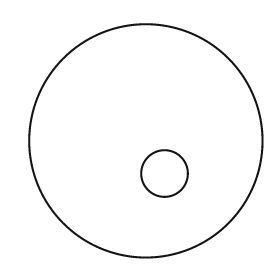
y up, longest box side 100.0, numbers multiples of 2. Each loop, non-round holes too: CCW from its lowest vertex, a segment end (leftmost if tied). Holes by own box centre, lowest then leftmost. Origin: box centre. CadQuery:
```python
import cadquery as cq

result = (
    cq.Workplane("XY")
    .moveTo(0.0, 0.0)
    .circle(50.0)
    .moveTo(8.0, -14.0)
    .circle(10.0)
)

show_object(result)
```